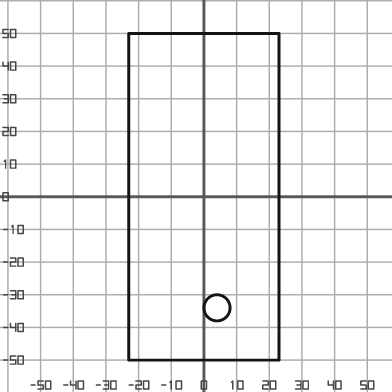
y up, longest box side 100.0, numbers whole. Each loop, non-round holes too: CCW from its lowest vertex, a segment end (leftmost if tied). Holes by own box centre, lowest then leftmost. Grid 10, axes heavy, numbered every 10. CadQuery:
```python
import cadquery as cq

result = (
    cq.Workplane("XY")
    .moveTo(-23.0, -50.0)
    .lineTo(23.0, -50.0)
    .lineTo(23.0, 50.0)
    .lineTo(-23.0, 50.0)
    .close()
    .moveTo(4.0, -34.0)
    .circle(4.0)
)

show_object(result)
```